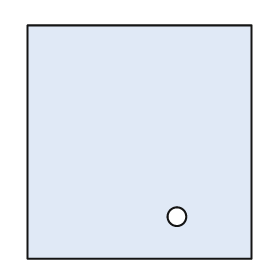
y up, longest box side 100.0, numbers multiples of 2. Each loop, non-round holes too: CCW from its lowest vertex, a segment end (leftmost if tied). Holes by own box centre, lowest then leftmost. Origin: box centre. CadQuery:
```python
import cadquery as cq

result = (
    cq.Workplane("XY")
    .moveTo(-48.0, -50.0)
    .lineTo(48.0, -50.0)
    .lineTo(48.0, 50.0)
    .lineTo(-48.0, 50.0)
    .close()
    .moveTo(16.0, -32.0)
    .circle(4.0)
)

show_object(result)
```